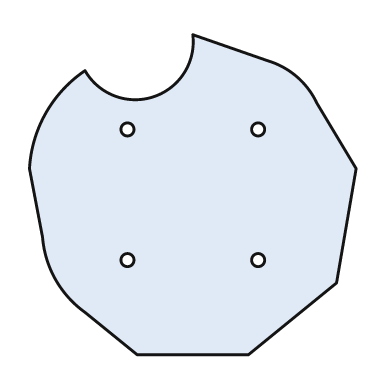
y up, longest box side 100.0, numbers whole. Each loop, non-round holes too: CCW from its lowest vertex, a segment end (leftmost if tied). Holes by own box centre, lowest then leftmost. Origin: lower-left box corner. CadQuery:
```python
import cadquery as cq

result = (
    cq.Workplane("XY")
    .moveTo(33.0, 0.0)
    .lineTo(67.0, 0.0)
    .lineTo(94.0, 22.0)
    .lineTo(100.0, 57.0)
    .lineTo(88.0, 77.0)
    .threePointArc((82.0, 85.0), (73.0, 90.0))
    .lineTo(50.0, 98.0)
    .threePointArc((38.0, 79.0), (17.0, 87.0))
    .threePointArc((5.0, 74.0), (0.0, 57.0))
    .lineTo(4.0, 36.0)
    .threePointArc((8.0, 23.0), (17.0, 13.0))
    .close()
    .moveTo(30.0, 29.0)
    .circle(2.0)
    .moveTo(70.0, 29.0)
    .circle(2.0)
    .moveTo(30.0, 69.0)
    .circle(2.0)
    .moveTo(70.0, 69.0)
    .circle(2.0)
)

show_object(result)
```